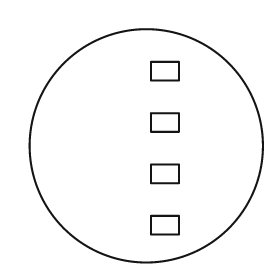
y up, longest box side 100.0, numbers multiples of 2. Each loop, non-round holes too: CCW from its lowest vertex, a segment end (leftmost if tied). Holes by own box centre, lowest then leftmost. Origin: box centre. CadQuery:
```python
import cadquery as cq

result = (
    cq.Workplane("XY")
    .moveTo(0.0, 0.0)
    .circle(50.0)
    .moveTo(2.0, -38.0)
    .lineTo(14.0, -38.0)
    .lineTo(14.0, -30.0)
    .lineTo(2.0, -30.0)
    .close()
    .moveTo(2.0, -16.0)
    .lineTo(14.0, -16.0)
    .lineTo(14.0, -8.0)
    .lineTo(2.0, -8.0)
    .close()
    .moveTo(2.0, 6.0)
    .lineTo(14.0, 6.0)
    .lineTo(14.0, 14.0)
    .lineTo(2.0, 14.0)
    .close()
    .moveTo(2.0, 28.0)
    .lineTo(14.0, 28.0)
    .lineTo(14.0, 36.0)
    .lineTo(2.0, 36.0)
    .close()
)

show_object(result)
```